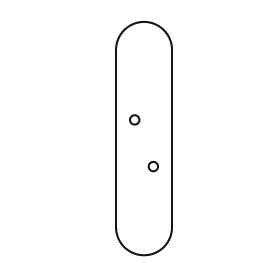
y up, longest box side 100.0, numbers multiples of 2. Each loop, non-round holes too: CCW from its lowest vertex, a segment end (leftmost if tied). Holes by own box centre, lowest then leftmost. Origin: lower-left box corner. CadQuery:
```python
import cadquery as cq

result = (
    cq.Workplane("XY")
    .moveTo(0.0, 12.0)
    .threePointArc((12.0, 0.0), (24.0, 12.0))
    .lineTo(24.0, 88.0)
    .threePointArc((12.0, 100.0), (0.0, 88.0))
    .close()
    .moveTo(16.0, 38.0)
    .circle(2.0)
    .moveTo(8.0, 58.0)
    .circle(2.0)
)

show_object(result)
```